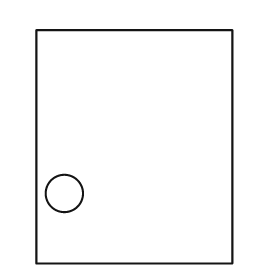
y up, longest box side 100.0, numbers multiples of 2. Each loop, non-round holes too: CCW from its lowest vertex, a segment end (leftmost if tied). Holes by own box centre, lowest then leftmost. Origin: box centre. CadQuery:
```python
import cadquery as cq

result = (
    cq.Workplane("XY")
    .moveTo(-42.0, -50.0)
    .lineTo(42.0, -50.0)
    .lineTo(42.0, 50.0)
    .lineTo(-42.0, 50.0)
    .close()
    .moveTo(-30.0, -20.0)
    .circle(8.0)
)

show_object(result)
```